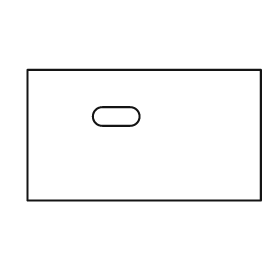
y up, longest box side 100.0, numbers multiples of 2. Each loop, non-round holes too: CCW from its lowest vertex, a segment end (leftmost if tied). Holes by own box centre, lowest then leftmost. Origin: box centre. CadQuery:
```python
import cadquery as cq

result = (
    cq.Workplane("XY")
    .moveTo(-50.0, -28.0)
    .lineTo(50.0, -28.0)
    .lineTo(50.0, 28.0)
    .lineTo(-50.0, 28.0)
    .close()
    .moveTo(-18.0, 4.0)
    .lineTo(-6.0, 4.0)
    .threePointArc((-2.0, 8.0), (-6.0, 12.0))
    .lineTo(-18.0, 12.0)
    .threePointArc((-22.0, 8.0), (-18.0, 4.0))
    .close()
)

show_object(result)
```